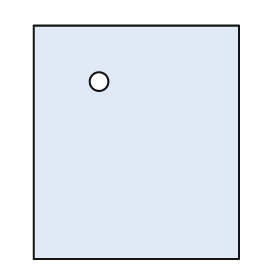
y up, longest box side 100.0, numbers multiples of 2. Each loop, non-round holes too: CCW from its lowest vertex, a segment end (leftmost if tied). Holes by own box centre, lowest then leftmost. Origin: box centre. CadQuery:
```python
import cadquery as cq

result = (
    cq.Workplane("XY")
    .moveTo(-44.0, -50.0)
    .lineTo(44.0, -50.0)
    .lineTo(44.0, 50.0)
    .lineTo(-44.0, 50.0)
    .close()
    .moveTo(-16.0, 26.0)
    .circle(4.0)
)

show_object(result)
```